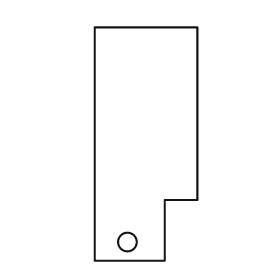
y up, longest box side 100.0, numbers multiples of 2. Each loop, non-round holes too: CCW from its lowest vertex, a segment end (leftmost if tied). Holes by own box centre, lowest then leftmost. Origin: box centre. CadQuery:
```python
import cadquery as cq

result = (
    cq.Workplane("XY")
    .moveTo(-22.0, -50.0)
    .lineTo(8.0, -50.0)
    .lineTo(8.0, -24.0)
    .lineTo(22.0, -24.0)
    .lineTo(22.0, 50.0)
    .lineTo(-22.0, 50.0)
    .close()
    .moveTo(-8.0, -42.0)
    .circle(4.0)
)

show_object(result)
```